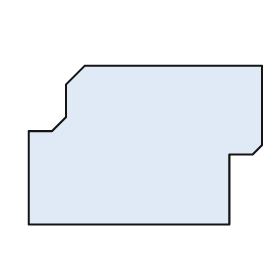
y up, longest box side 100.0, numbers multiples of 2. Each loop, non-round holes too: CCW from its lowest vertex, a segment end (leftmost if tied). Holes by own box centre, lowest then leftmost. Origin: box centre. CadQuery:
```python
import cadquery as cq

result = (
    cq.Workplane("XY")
    .moveTo(-50.0, -34.0)
    .lineTo(36.0, -34.0)
    .lineTo(36.0, -4.0)
    .lineTo(46.0, -4.0)
    .lineTo(50.0, 0.0)
    .lineTo(50.0, 34.0)
    .lineTo(-26.0, 34.0)
    .lineTo(-34.0, 26.0)
    .lineTo(-34.0, 12.0)
    .lineTo(-40.0, 6.0)
    .lineTo(-50.0, 6.0)
    .close()
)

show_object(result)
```